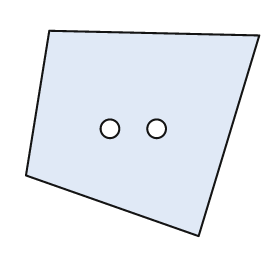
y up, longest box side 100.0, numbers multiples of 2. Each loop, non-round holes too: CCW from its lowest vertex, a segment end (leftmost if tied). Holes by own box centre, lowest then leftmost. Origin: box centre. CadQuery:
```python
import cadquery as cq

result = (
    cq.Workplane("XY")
    .moveTo(24.0, -44.0)
    .lineTo(50.0, 42.0)
    .lineTo(-40.0, 44.0)
    .lineTo(-50.0, -18.0)
    .close()
    .moveTo(-14.0, 2.0)
    .circle(4.0)
    .moveTo(6.0, 2.0)
    .circle(4.0)
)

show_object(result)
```